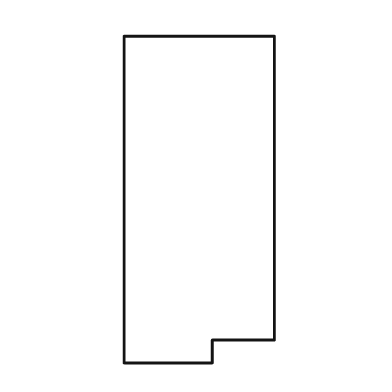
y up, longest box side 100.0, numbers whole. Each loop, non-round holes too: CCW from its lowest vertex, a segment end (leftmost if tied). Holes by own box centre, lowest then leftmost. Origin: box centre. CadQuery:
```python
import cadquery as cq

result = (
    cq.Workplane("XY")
    .moveTo(-23.0, -50.0)
    .lineTo(4.0, -50.0)
    .lineTo(4.0, -43.0)
    .lineTo(23.0, -43.0)
    .lineTo(23.0, 50.0)
    .lineTo(-23.0, 50.0)
    .close()
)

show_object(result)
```